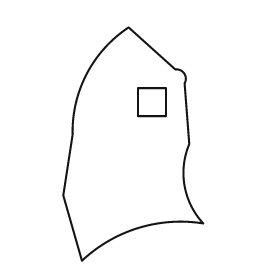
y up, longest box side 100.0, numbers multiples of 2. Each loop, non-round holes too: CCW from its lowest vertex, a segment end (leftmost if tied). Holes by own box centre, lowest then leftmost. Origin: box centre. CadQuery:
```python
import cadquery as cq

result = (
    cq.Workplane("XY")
    .moveTo(-22.0, -50.0)
    .threePointArc((2.0, -36.0), (30.0, -34.0))
    .threePointArc((22.0, -18.0), (24.0, 0.0))
    .lineTo(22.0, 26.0)
    .threePointArc((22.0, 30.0), (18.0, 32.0))
    .lineTo(-2.0, 50.0)
    .threePointArc((-20.0, 30.0), (-26.0, 4.0))
    .lineTo(-30.0, -22.0)
    .close()
    .moveTo(2.0, 12.0)
    .lineTo(14.0, 12.0)
    .lineTo(14.0, 24.0)
    .lineTo(2.0, 24.0)
    .close()
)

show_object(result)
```